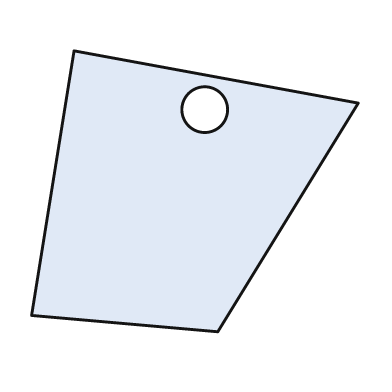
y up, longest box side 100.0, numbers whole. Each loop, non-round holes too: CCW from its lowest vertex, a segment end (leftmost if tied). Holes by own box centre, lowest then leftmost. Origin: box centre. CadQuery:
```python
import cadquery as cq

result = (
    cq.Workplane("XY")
    .moveTo(7.0, -43.0)
    .lineTo(50.0, 27.0)
    .lineTo(-37.0, 43.0)
    .lineTo(-50.0, -38.0)
    .close()
    .moveTo(3.0, 25.0)
    .circle(7.0)
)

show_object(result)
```